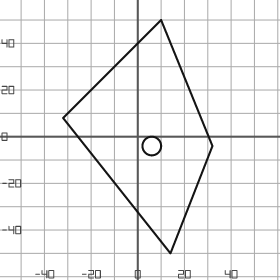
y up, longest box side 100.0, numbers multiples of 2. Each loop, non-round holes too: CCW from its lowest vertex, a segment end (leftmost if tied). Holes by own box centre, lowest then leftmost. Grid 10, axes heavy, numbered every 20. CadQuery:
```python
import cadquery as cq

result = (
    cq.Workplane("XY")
    .moveTo(14.0, -50.0)
    .lineTo(32.0, -4.0)
    .lineTo(10.0, 50.0)
    .lineTo(-32.0, 8.0)
    .close()
    .moveTo(6.0, -4.0)
    .circle(4.0)
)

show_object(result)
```